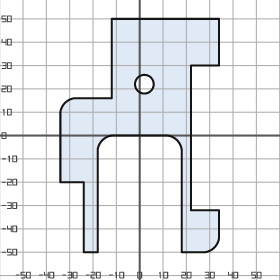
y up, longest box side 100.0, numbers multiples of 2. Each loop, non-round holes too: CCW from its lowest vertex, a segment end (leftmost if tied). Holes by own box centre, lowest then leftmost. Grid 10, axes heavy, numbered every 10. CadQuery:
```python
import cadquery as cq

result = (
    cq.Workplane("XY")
    .moveTo(-24.0, -50.0)
    .lineTo(-18.0, -50.0)
    .lineTo(-18.0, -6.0)
    .threePointArc((-16.0, -2.0), (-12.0, 0.0))
    .lineTo(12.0, 0.0)
    .threePointArc((16.0, -2.0), (18.0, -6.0))
    .lineTo(18.0, -50.0)
    .lineTo(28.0, -50.0)
    .threePointArc((32.0, -48.0), (34.0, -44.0))
    .lineTo(34.0, -32.0)
    .lineTo(22.0, -32.0)
    .lineTo(22.0, 30.0)
    .lineTo(34.0, 30.0)
    .lineTo(34.0, 50.0)
    .lineTo(-12.0, 50.0)
    .lineTo(-12.0, 16.0)
    .lineTo(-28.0, 16.0)
    .threePointArc((-32.0, 14.0), (-34.0, 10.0))
    .lineTo(-34.0, -20.0)
    .lineTo(-24.0, -20.0)
    .close()
    .moveTo(2.0, 22.0)
    .circle(4.0)
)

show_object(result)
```